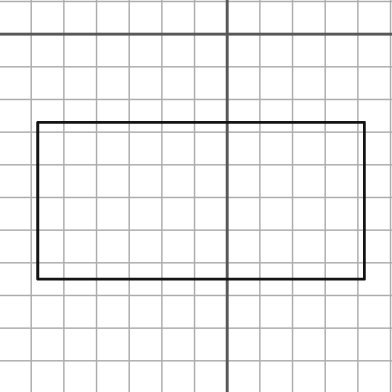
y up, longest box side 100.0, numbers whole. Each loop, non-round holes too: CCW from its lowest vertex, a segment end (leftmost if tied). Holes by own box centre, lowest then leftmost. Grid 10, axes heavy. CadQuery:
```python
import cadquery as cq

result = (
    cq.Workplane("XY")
    .moveTo(-58.0, -75.0)
    .lineTo(42.0, -75.0)
    .lineTo(42.0, -27.0)
    .lineTo(-58.0, -27.0)
    .close()
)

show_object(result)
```